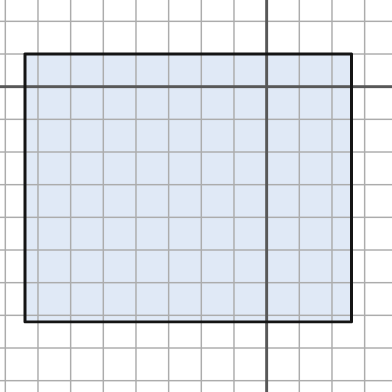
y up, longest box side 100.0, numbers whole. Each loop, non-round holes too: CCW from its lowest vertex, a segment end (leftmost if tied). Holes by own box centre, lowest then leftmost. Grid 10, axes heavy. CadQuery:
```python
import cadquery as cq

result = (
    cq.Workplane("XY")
    .moveTo(-74.0, -72.0)
    .lineTo(26.0, -72.0)
    .lineTo(26.0, 10.0)
    .lineTo(-74.0, 10.0)
    .close()
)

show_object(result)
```